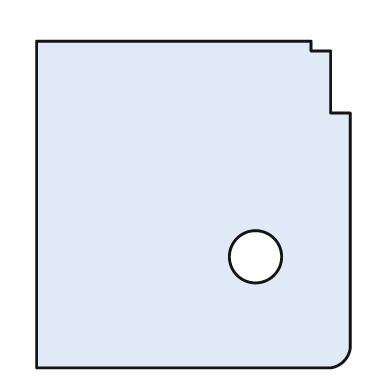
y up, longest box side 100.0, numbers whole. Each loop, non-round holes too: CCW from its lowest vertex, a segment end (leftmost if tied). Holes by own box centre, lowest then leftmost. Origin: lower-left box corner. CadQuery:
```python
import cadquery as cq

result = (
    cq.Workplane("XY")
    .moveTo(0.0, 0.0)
    .lineTo(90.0, 0.0)
    .threePointArc((94.0, 2.0), (96.0, 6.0))
    .lineTo(96.0, 78.0)
    .lineTo(90.0, 78.0)
    .lineTo(90.0, 97.0)
    .lineTo(84.0, 97.0)
    .lineTo(84.0, 100.0)
    .lineTo(0.0, 100.0)
    .close()
    .moveTo(67.0, 34.0)
    .circle(8.0)
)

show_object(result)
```